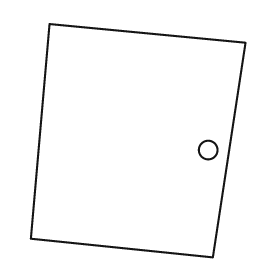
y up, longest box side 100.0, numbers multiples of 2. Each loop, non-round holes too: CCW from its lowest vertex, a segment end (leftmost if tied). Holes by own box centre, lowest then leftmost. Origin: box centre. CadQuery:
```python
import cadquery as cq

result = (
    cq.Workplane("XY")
    .moveTo(32.0, -50.0)
    .lineTo(46.0, 42.0)
    .lineTo(-38.0, 50.0)
    .lineTo(-46.0, -42.0)
    .close()
    .moveTo(30.0, -4.0)
    .circle(4.0)
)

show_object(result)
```